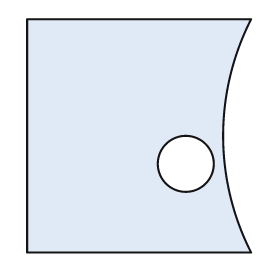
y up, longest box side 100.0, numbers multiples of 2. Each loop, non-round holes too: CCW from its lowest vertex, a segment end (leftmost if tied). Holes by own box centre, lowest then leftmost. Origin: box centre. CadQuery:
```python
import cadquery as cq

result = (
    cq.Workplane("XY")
    .moveTo(-48.0, -50.0)
    .lineTo(48.0, -50.0)
    .threePointArc((36.0, 0.0), (48.0, 50.0))
    .lineTo(-48.0, 50.0)
    .close()
    .moveTo(20.0, -12.0)
    .circle(12.0)
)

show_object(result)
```